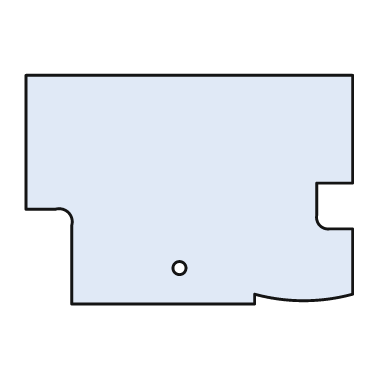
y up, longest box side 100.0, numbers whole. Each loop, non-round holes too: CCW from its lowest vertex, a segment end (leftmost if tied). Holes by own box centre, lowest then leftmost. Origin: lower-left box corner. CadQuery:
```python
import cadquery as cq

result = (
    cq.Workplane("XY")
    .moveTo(14.0, 0.0)
    .lineTo(70.0, 0.0)
    .lineTo(70.0, 3.0)
    .threePointArc((85.0, 1.0), (100.0, 3.0))
    .lineTo(100.0, 23.0)
    .lineTo(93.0, 23.0)
    .threePointArc((90.0, 24.0), (89.0, 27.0))
    .lineTo(89.0, 37.0)
    .lineTo(100.0, 37.0)
    .lineTo(100.0, 70.0)
    .lineTo(0.0, 70.0)
    .lineTo(0.0, 29.0)
    .lineTo(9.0, 29.0)
    .threePointArc((13.0, 28.0), (14.0, 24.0))
    .close()
    .moveTo(47.0, 11.0)
    .circle(2.0)
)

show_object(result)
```